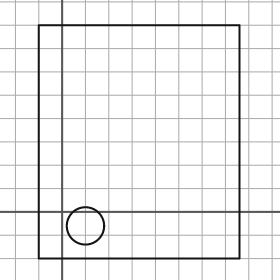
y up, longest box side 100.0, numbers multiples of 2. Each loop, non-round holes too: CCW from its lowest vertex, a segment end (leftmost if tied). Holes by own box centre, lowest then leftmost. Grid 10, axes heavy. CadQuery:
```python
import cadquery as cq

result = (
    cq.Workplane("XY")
    .moveTo(-10.0, -20.0)
    .lineTo(76.0, -20.0)
    .lineTo(76.0, 80.0)
    .lineTo(-10.0, 80.0)
    .close()
    .moveTo(10.0, -6.0)
    .circle(8.0)
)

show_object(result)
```